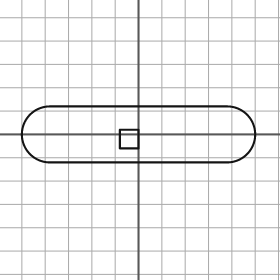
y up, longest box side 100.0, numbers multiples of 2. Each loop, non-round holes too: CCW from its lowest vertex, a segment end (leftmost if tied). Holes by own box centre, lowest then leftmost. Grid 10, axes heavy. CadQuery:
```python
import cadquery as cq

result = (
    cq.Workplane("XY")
    .moveTo(-38.0, -12.0)
    .lineTo(38.0, -12.0)
    .threePointArc((50.0, 0.0), (38.0, 12.0))
    .lineTo(-38.0, 12.0)
    .threePointArc((-50.0, 0.0), (-38.0, -12.0))
    .close()
    .moveTo(-8.0, -6.0)
    .lineTo(0.0, -6.0)
    .lineTo(0.0, 2.0)
    .lineTo(-8.0, 2.0)
    .close()
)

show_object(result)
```